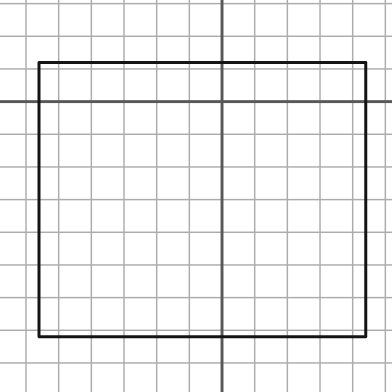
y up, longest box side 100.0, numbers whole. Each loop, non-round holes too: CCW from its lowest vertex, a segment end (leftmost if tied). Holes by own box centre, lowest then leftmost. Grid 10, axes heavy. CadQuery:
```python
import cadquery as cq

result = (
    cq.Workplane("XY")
    .moveTo(-56.0, -72.0)
    .lineTo(44.0, -72.0)
    .lineTo(44.0, 12.0)
    .lineTo(-56.0, 12.0)
    .close()
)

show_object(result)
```